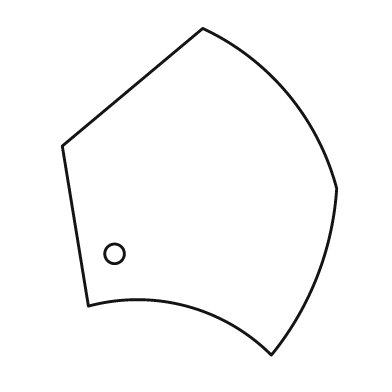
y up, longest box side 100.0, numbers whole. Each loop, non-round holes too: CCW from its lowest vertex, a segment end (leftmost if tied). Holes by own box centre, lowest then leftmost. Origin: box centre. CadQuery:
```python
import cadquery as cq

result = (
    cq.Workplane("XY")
    .moveTo(22.0, -50.0)
    .threePointArc((36.0, -26.0), (42.0, 1.0))
    .threePointArc((27.0, 30.0), (1.0, 50.0))
    .lineTo(-42.0, 14.0)
    .lineTo(-34.0, -35.0)
    .threePointArc((-4.0, -35.0), (22.0, -50.0))
    .close()
    .moveTo(-26.0, -19.0)
    .circle(3.0)
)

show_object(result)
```